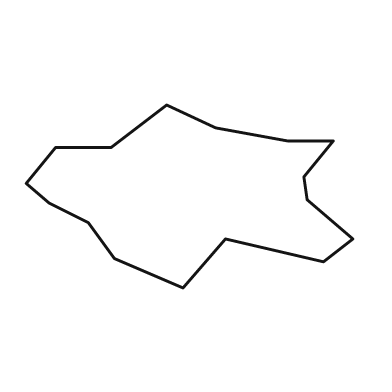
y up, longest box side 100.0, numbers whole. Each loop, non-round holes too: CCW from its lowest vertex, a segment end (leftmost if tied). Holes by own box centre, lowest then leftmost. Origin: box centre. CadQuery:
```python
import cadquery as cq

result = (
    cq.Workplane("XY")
    .moveTo(-2.0, -28.0)
    .lineTo(11.0, -13.0)
    .lineTo(41.0, -20.0)
    .lineTo(50.0, -13.0)
    .lineTo(36.0, -1.0)
    .lineTo(35.0, 6.0)
    .lineTo(44.0, 17.0)
    .lineTo(30.0, 17.0)
    .lineTo(8.0, 21.0)
    .lineTo(-7.0, 28.0)
    .lineTo(-24.0, 15.0)
    .lineTo(-41.0, 15.0)
    .lineTo(-50.0, 4.0)
    .lineTo(-43.0, -2.0)
    .lineTo(-31.0, -8.0)
    .lineTo(-23.0, -19.0)
    .close()
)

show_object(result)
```